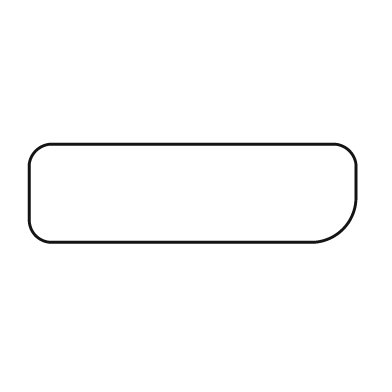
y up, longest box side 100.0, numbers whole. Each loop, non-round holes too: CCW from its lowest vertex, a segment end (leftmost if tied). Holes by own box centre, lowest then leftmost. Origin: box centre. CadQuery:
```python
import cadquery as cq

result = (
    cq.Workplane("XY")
    .moveTo(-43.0, -15.0)
    .lineTo(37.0, -15.0)
    .threePointArc((46.0, -11.0), (50.0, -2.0))
    .lineTo(50.0, 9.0)
    .threePointArc((48.0, 13.0), (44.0, 15.0))
    .lineTo(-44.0, 15.0)
    .threePointArc((-48.0, 13.0), (-50.0, 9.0))
    .lineTo(-50.0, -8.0)
    .threePointArc((-48.0, -13.0), (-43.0, -15.0))
    .close()
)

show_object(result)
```